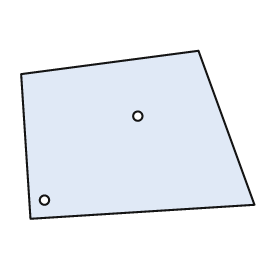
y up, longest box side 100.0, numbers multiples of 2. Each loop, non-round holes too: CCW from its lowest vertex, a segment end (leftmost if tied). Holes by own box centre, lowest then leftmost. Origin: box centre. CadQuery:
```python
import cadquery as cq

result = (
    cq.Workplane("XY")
    .moveTo(-46.0, -36.0)
    .lineTo(50.0, -30.0)
    .lineTo(26.0, 36.0)
    .lineTo(-50.0, 26.0)
    .close()
    .moveTo(-40.0, -28.0)
    .circle(2.0)
    .moveTo(0.0, 8.0)
    .circle(2.0)
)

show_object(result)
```